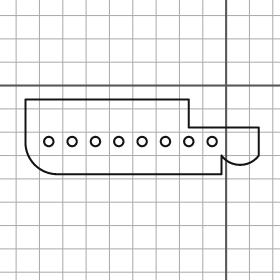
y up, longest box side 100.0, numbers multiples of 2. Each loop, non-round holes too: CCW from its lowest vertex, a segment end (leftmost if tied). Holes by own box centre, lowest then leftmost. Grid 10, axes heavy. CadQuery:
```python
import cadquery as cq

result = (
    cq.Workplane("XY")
    .moveTo(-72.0, -38.0)
    .lineTo(-2.0, -38.0)
    .lineTo(-2.0, -30.0)
    .threePointArc((6.0, -34.0), (14.0, -30.0))
    .lineTo(14.0, -18.0)
    .lineTo(-16.0, -18.0)
    .lineTo(-16.0, -6.0)
    .lineTo(-86.0, -6.0)
    .lineTo(-86.0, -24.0)
    .threePointArc((-82.0, -34.0), (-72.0, -38.0))
    .close()
    .moveTo(-76.0, -24.0)
    .circle(2.0)
    .moveTo(-66.0, -24.0)
    .circle(2.0)
    .moveTo(-56.0, -24.0)
    .circle(2.0)
    .moveTo(-46.0, -24.0)
    .circle(2.0)
    .moveTo(-36.0, -24.0)
    .circle(2.0)
    .moveTo(-26.0, -24.0)
    .circle(2.0)
    .moveTo(-16.0, -24.0)
    .circle(2.0)
    .moveTo(-6.0, -24.0)
    .circle(2.0)
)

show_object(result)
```